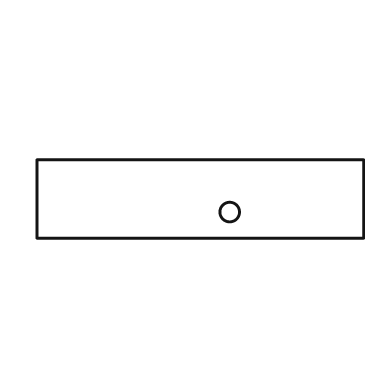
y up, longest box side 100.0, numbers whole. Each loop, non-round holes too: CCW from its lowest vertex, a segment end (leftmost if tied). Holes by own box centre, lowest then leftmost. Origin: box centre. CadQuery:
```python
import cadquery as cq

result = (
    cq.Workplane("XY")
    .moveTo(-50.0, -12.0)
    .lineTo(50.0, -12.0)
    .lineTo(50.0, 12.0)
    .lineTo(-50.0, 12.0)
    .close()
    .moveTo(9.0, -4.0)
    .circle(3.0)
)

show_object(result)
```